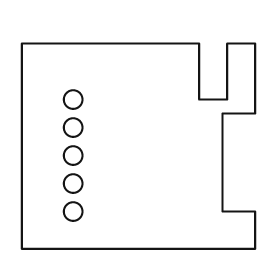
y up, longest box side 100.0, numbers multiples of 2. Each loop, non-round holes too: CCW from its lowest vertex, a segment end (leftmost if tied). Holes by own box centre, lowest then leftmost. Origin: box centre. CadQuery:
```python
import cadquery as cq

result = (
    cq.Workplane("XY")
    .moveTo(-50.0, -44.0)
    .lineTo(50.0, -44.0)
    .lineTo(50.0, -28.0)
    .lineTo(36.0, -28.0)
    .lineTo(36.0, 14.0)
    .lineTo(50.0, 14.0)
    .lineTo(50.0, 44.0)
    .lineTo(38.0, 44.0)
    .lineTo(38.0, 20.0)
    .lineTo(26.0, 20.0)
    .lineTo(26.0, 44.0)
    .lineTo(-50.0, 44.0)
    .close()
    .moveTo(-28.0, -28.0)
    .circle(4.0)
    .moveTo(-28.0, -16.0)
    .circle(4.0)
    .moveTo(-28.0, -4.0)
    .circle(4.0)
    .moveTo(-28.0, 8.0)
    .circle(4.0)
    .moveTo(-28.0, 20.0)
    .circle(4.0)
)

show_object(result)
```